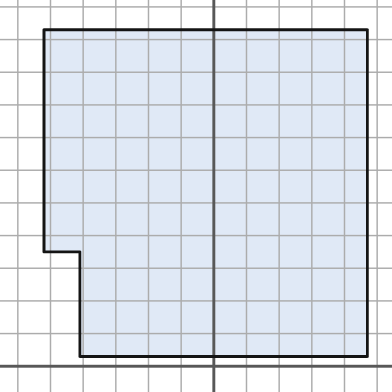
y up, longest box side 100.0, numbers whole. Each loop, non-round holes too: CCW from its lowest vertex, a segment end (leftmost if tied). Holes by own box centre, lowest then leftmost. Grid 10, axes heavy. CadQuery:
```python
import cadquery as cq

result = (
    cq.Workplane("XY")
    .moveTo(-41.0, 3.0)
    .lineTo(47.0, 3.0)
    .lineTo(47.0, 103.0)
    .lineTo(-52.0, 103.0)
    .lineTo(-52.0, 35.0)
    .lineTo(-41.0, 35.0)
    .close()
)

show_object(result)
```